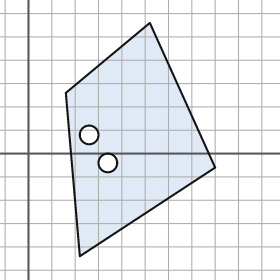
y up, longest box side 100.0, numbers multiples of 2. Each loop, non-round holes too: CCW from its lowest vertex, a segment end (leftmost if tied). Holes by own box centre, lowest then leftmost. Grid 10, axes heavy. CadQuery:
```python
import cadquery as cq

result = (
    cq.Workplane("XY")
    .moveTo(22.0, -44.0)
    .lineTo(80.0, -6.0)
    .lineTo(52.0, 56.0)
    .lineTo(16.0, 26.0)
    .close()
    .moveTo(34.0, -4.0)
    .circle(4.0)
    .moveTo(26.0, 8.0)
    .circle(4.0)
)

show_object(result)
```